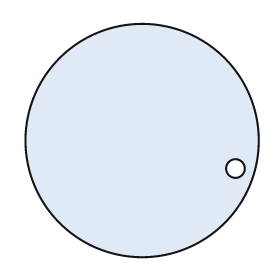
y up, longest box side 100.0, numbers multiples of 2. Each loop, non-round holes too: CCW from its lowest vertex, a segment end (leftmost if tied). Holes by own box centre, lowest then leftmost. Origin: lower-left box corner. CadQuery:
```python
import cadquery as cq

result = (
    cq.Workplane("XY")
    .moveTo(50.0, 50.0)
    .circle(50.0)
    .moveTo(90.0, 38.0)
    .circle(4.0)
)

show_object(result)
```